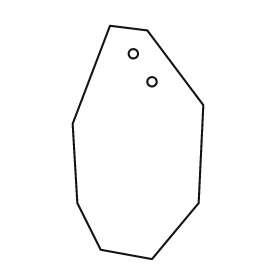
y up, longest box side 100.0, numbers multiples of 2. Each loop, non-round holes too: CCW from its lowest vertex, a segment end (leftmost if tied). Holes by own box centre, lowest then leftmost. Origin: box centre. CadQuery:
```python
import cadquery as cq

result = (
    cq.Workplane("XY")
    .moveTo(6.0, -50.0)
    .lineTo(26.0, -26.0)
    .lineTo(28.0, 16.0)
    .lineTo(4.0, 48.0)
    .lineTo(-12.0, 50.0)
    .lineTo(-28.0, 8.0)
    .lineTo(-26.0, -26.0)
    .lineTo(-16.0, -46.0)
    .close()
    .moveTo(6.0, 26.0)
    .circle(2.0)
    .moveTo(-2.0, 38.0)
    .circle(2.0)
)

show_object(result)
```